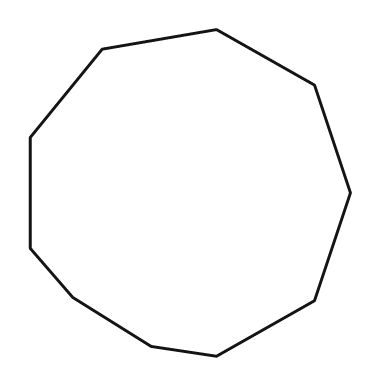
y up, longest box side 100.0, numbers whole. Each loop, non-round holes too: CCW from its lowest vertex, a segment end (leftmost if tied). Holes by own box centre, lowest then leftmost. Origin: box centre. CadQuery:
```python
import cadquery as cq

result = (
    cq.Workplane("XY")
    .moveTo(8.0, -50.0)
    .lineTo(38.0, -33.0)
    .lineTo(49.0, 0.0)
    .lineTo(38.0, 33.0)
    .lineTo(8.0, 50.0)
    .lineTo(-27.0, 44.0)
    .lineTo(-49.0, 17.0)
    .lineTo(-49.0, -17.0)
    .lineTo(-36.0, -32.0)
    .lineTo(-12.0, -47.0)
    .close()
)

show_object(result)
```